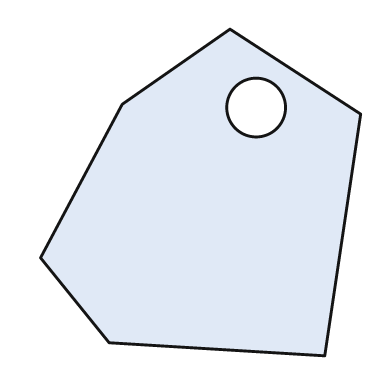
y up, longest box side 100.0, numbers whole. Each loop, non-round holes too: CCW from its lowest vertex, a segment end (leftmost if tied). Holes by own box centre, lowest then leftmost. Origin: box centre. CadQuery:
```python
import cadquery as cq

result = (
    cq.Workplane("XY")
    .moveTo(38.0, -50.0)
    .lineTo(49.0, 24.0)
    .lineTo(9.0, 50.0)
    .lineTo(-24.0, 27.0)
    .lineTo(-49.0, -20.0)
    .lineTo(-28.0, -46.0)
    .close()
    .moveTo(17.0, 26.0)
    .circle(9.0)
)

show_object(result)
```